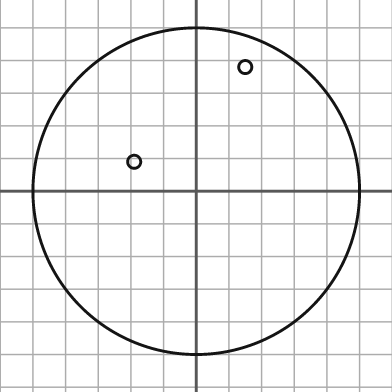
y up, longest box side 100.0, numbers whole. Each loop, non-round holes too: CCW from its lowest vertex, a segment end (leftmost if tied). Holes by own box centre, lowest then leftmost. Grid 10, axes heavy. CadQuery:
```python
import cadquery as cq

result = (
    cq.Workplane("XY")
    .moveTo(0.0, 0.0)
    .circle(50.0)
    .moveTo(-19.0, 9.0)
    .circle(2.0)
    .moveTo(15.0, 38.0)
    .circle(2.0)
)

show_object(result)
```